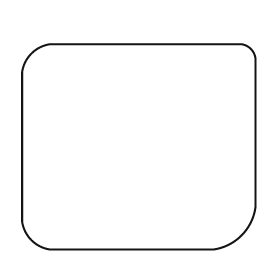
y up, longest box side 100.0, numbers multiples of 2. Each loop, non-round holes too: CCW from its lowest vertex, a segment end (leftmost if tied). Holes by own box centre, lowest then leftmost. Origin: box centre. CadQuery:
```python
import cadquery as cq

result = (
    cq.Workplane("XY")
    .moveTo(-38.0, -44.0)
    .lineTo(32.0, -44.0)
    .threePointArc((44.0, -38.0), (50.0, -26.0))
    .lineTo(50.0, 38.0)
    .threePointArc((48.0, 42.0), (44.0, 44.0))
    .lineTo(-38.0, 44.0)
    .threePointArc((-46.0, 40.0), (-50.0, 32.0))
    .lineTo(-50.0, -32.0)
    .threePointArc((-46.0, -40.0), (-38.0, -44.0))
    .close()
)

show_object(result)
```